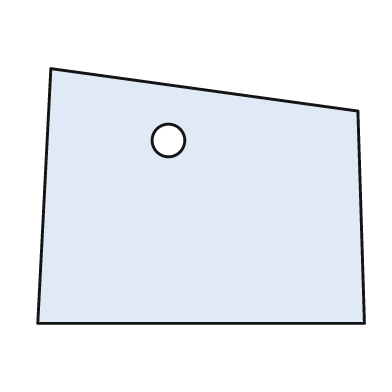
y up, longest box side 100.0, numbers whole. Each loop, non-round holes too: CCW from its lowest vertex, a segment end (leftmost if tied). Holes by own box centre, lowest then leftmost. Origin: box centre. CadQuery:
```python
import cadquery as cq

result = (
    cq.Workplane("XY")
    .moveTo(-50.0, -39.0)
    .lineTo(50.0, -39.0)
    .lineTo(48.0, 26.0)
    .lineTo(-46.0, 39.0)
    .close()
    .moveTo(-10.0, 17.0)
    .circle(5.0)
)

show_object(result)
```